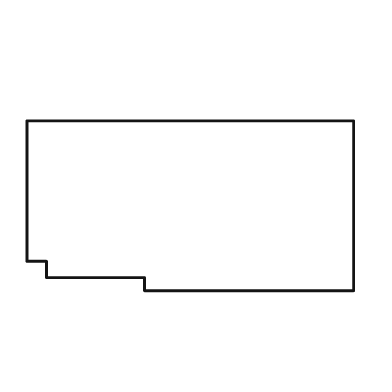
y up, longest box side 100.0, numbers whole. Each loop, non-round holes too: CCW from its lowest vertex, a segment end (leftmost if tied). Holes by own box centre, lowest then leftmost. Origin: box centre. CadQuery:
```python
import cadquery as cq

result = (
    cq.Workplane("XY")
    .moveTo(-14.0, -26.0)
    .lineTo(50.0, -26.0)
    .lineTo(50.0, 26.0)
    .lineTo(-50.0, 26.0)
    .lineTo(-50.0, -17.0)
    .lineTo(-44.0, -17.0)
    .lineTo(-44.0, -22.0)
    .lineTo(-14.0, -22.0)
    .close()
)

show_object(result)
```